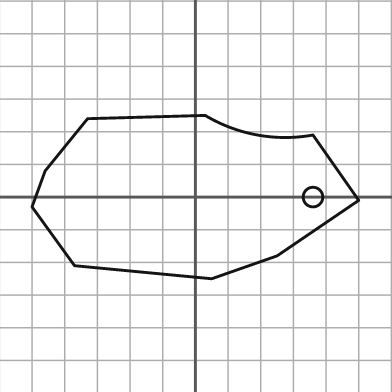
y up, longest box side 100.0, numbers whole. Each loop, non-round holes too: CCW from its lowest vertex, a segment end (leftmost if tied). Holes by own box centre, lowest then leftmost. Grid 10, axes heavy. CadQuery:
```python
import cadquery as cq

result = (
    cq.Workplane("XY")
    .moveTo(5.0, -25.0)
    .lineTo(25.0, -18.0)
    .lineTo(50.0, -1.0)
    .lineTo(36.0, 19.0)
    .threePointArc((19.0, 19.0), (3.0, 25.0))
    .lineTo(-33.0, 24.0)
    .lineTo(-46.0, 8.0)
    .lineTo(-50.0, -3.0)
    .lineTo(-37.0, -21.0)
    .close()
    .moveTo(36.0, 0.0)
    .circle(3.0)
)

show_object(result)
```